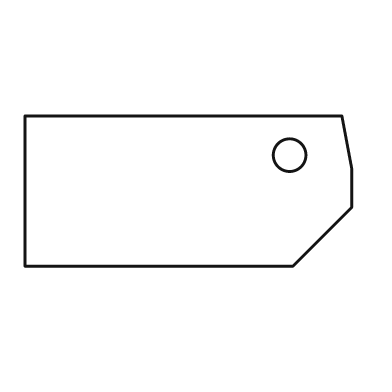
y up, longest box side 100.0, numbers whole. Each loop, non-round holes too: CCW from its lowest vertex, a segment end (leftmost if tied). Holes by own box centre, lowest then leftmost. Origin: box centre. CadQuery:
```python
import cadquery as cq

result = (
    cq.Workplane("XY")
    .moveTo(-50.0, -23.0)
    .lineTo(32.0, -23.0)
    .lineTo(50.0, -5.0)
    .lineTo(50.0, 7.0)
    .lineTo(47.0, 23.0)
    .lineTo(-50.0, 23.0)
    .close()
    .moveTo(31.0, 11.0)
    .circle(5.0)
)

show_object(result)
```